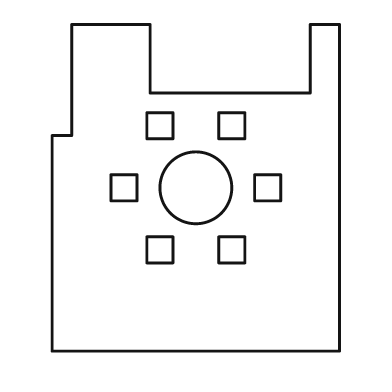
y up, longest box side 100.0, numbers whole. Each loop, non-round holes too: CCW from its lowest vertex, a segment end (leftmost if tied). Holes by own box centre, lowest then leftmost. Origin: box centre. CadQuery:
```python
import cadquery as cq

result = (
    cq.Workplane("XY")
    .moveTo(-44.0, -50.0)
    .lineTo(44.0, -50.0)
    .lineTo(44.0, 50.0)
    .lineTo(35.0, 50.0)
    .lineTo(35.0, 29.0)
    .lineTo(-14.0, 29.0)
    .lineTo(-14.0, 50.0)
    .lineTo(-38.0, 50.0)
    .lineTo(-38.0, 16.0)
    .lineTo(-44.0, 16.0)
    .close()
    .moveTo(-15.0, -23.0)
    .lineTo(-7.0, -23.0)
    .lineTo(-7.0, -15.0)
    .lineTo(-15.0, -15.0)
    .close()
    .moveTo(7.0, -23.0)
    .lineTo(15.0, -23.0)
    .lineTo(15.0, -15.0)
    .lineTo(7.0, -15.0)
    .close()
    .moveTo(-26.0, -4.0)
    .lineTo(-18.0, -4.0)
    .lineTo(-18.0, 4.0)
    .lineTo(-26.0, 4.0)
    .close()
    .moveTo(0.0, 0.0)
    .circle(11.0)
    .moveTo(18.0, -4.0)
    .lineTo(26.0, -4.0)
    .lineTo(26.0, 4.0)
    .lineTo(18.0, 4.0)
    .close()
    .moveTo(-15.0, 15.0)
    .lineTo(-7.0, 15.0)
    .lineTo(-7.0, 23.0)
    .lineTo(-15.0, 23.0)
    .close()
    .moveTo(7.0, 15.0)
    .lineTo(15.0, 15.0)
    .lineTo(15.0, 23.0)
    .lineTo(7.0, 23.0)
    .close()
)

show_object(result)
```